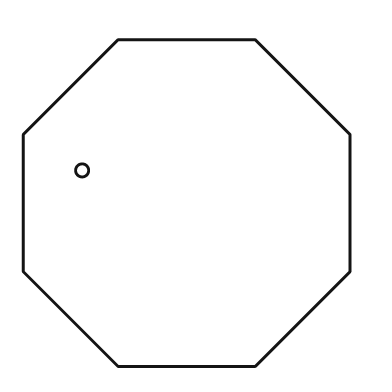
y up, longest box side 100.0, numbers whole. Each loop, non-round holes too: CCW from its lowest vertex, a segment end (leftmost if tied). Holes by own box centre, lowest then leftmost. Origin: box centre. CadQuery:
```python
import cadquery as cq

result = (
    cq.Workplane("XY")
    .moveTo(-21.0, -50.0)
    .lineTo(21.0, -50.0)
    .lineTo(50.0, -21.0)
    .lineTo(50.0, 21.0)
    .lineTo(21.0, 50.0)
    .lineTo(-21.0, 50.0)
    .lineTo(-50.0, 21.0)
    .lineTo(-50.0, -21.0)
    .close()
    .moveTo(-32.0, 10.0)
    .circle(2.0)
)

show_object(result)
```